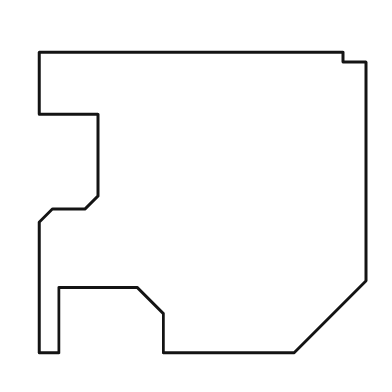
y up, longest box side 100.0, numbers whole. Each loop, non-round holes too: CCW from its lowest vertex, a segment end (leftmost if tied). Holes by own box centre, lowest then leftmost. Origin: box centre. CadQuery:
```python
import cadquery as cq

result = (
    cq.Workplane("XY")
    .moveTo(-50.0, -46.0)
    .lineTo(-44.0, -46.0)
    .lineTo(-44.0, -26.0)
    .lineTo(-20.0, -26.0)
    .lineTo(-12.0, -34.0)
    .lineTo(-12.0, -46.0)
    .lineTo(28.0, -46.0)
    .lineTo(50.0, -24.0)
    .lineTo(50.0, 43.0)
    .lineTo(43.0, 43.0)
    .lineTo(43.0, 46.0)
    .lineTo(-50.0, 46.0)
    .lineTo(-50.0, 27.0)
    .lineTo(-32.0, 27.0)
    .lineTo(-32.0, 2.0)
    .lineTo(-36.0, -2.0)
    .lineTo(-46.0, -2.0)
    .lineTo(-50.0, -6.0)
    .close()
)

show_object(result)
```